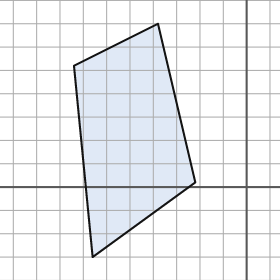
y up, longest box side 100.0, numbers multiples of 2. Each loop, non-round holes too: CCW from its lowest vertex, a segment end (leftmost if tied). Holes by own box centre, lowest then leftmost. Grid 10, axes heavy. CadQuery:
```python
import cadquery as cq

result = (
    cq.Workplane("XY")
    .moveTo(-66.0, -30.0)
    .lineTo(-22.0, 2.0)
    .lineTo(-38.0, 70.0)
    .lineTo(-74.0, 52.0)
    .close()
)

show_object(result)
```